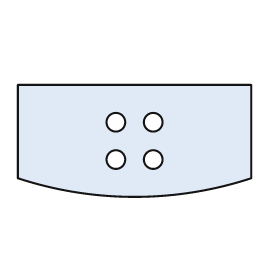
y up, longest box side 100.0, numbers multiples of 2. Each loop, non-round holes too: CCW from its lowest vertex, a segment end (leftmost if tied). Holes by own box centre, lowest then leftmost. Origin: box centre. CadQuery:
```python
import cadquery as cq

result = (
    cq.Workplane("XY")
    .moveTo(-50.0, -16.0)
    .threePointArc((0.0, -24.0), (50.0, -16.0))
    .lineTo(50.0, 24.0)
    .lineTo(-50.0, 24.0)
    .close()
    .moveTo(-8.0, -8.0)
    .circle(4.0)
    .moveTo(8.0, -8.0)
    .circle(4.0)
    .moveTo(-8.0, 8.0)
    .circle(4.0)
    .moveTo(8.0, 8.0)
    .circle(4.0)
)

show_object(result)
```